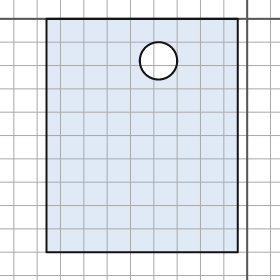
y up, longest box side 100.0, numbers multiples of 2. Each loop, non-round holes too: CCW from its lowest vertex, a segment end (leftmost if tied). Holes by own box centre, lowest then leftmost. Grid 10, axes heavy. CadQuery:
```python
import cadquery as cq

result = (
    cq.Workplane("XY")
    .moveTo(-86.0, -100.0)
    .lineTo(-4.0, -100.0)
    .lineTo(-4.0, 0.0)
    .lineTo(-86.0, 0.0)
    .close()
    .moveTo(-38.0, -18.0)
    .circle(8.0)
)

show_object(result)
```